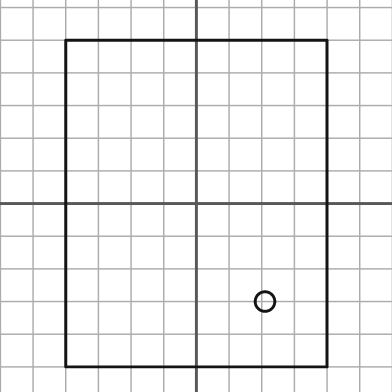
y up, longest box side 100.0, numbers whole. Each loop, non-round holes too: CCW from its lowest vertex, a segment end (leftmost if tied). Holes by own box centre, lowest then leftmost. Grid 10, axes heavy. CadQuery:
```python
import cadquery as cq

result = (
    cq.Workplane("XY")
    .moveTo(-40.0, -50.0)
    .lineTo(40.0, -50.0)
    .lineTo(40.0, 50.0)
    .lineTo(-40.0, 50.0)
    .close()
    .moveTo(21.0, -30.0)
    .circle(3.0)
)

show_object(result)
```